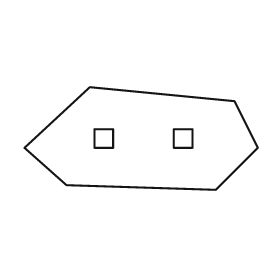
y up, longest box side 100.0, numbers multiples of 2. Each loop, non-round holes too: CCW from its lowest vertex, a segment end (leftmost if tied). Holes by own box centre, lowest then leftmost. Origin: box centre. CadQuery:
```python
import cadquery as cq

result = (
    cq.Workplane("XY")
    .moveTo(32.0, -22.0)
    .lineTo(50.0, -4.0)
    .lineTo(40.0, 16.0)
    .lineTo(-22.0, 22.0)
    .lineTo(-50.0, -4.0)
    .lineTo(-32.0, -20.0)
    .close()
    .moveTo(-20.0, -4.0)
    .lineTo(-12.0, -4.0)
    .lineTo(-12.0, 4.0)
    .lineTo(-20.0, 4.0)
    .close()
    .moveTo(14.0, -4.0)
    .lineTo(22.0, -4.0)
    .lineTo(22.0, 4.0)
    .lineTo(14.0, 4.0)
    .close()
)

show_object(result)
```